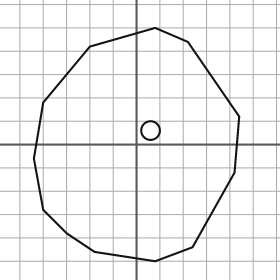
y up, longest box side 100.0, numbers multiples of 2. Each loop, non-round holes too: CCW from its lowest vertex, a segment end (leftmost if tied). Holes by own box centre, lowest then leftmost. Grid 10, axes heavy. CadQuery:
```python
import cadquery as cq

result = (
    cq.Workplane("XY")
    .moveTo(8.0, -50.0)
    .lineTo(24.0, -44.0)
    .lineTo(42.0, -12.0)
    .lineTo(44.0, 12.0)
    .lineTo(22.0, 44.0)
    .lineTo(8.0, 50.0)
    .lineTo(-20.0, 42.0)
    .lineTo(-40.0, 18.0)
    .lineTo(-44.0, -6.0)
    .lineTo(-40.0, -28.0)
    .lineTo(-30.0, -38.0)
    .lineTo(-18.0, -46.0)
    .close()
    .moveTo(6.0, 6.0)
    .circle(4.0)
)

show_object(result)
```